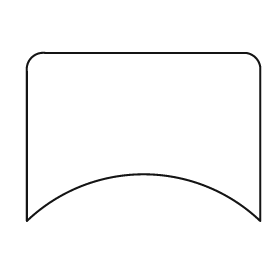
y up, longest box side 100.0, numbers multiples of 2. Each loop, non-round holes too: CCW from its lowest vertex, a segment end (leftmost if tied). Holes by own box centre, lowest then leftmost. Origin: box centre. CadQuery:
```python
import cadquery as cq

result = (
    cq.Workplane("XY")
    .moveTo(-50.0, -36.0)
    .threePointArc((0.0, -16.0), (50.0, -36.0))
    .lineTo(50.0, 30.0)
    .threePointArc((48.0, 34.0), (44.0, 36.0))
    .lineTo(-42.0, 36.0)
    .threePointArc((-48.0, 34.0), (-50.0, 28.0))
    .close()
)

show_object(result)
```